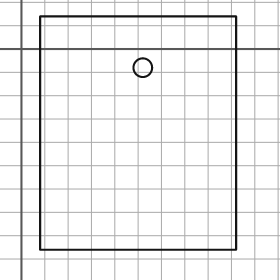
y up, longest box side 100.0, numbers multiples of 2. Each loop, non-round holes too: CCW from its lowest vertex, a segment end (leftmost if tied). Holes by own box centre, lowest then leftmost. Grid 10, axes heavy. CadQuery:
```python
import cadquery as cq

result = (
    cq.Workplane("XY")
    .moveTo(8.0, -86.0)
    .lineTo(92.0, -86.0)
    .lineTo(92.0, 14.0)
    .lineTo(8.0, 14.0)
    .close()
    .moveTo(52.0, -8.0)
    .circle(4.0)
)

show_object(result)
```